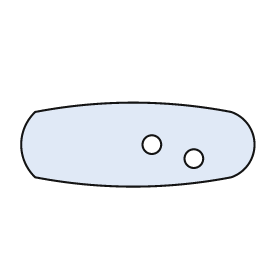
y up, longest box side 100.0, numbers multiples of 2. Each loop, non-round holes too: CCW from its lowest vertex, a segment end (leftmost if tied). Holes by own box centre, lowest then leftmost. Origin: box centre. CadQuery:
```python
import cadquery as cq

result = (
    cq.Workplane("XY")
    .moveTo(-44.0, -14.0)
    .threePointArc((-2.0, -18.0), (40.0, -14.0))
    .threePointArc((50.0, 0.0), (40.0, 14.0))
    .threePointArc((-2.0, 18.0), (-44.0, 14.0))
    .threePointArc((-50.0, 0.0), (-44.0, -14.0))
    .close()
    .moveTo(24.0, -6.0)
    .circle(4.0)
    .moveTo(6.0, 0.0)
    .circle(4.0)
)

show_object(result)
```